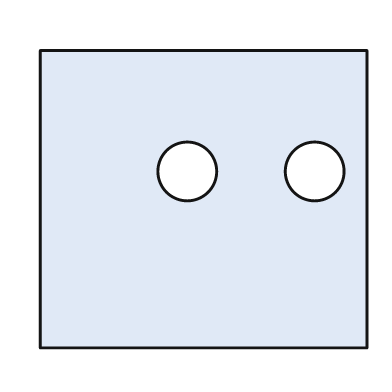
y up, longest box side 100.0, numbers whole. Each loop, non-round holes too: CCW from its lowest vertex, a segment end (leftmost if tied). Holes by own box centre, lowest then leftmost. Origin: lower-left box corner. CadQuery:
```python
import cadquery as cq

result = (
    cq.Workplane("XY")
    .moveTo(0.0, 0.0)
    .lineTo(100.0, 0.0)
    .lineTo(100.0, 91.0)
    .lineTo(0.0, 91.0)
    .close()
    .moveTo(45.0, 54.0)
    .circle(9.0)
    .moveTo(84.0, 54.0)
    .circle(9.0)
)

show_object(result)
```